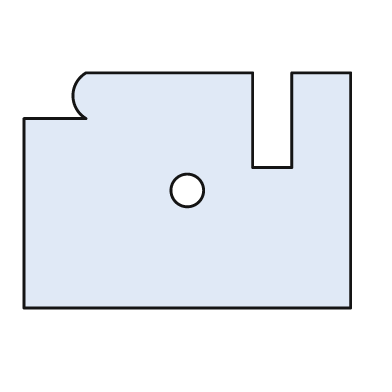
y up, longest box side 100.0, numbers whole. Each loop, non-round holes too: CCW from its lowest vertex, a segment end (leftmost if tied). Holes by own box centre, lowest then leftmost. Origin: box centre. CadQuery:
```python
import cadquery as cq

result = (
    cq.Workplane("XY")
    .moveTo(-50.0, -36.0)
    .lineTo(50.0, -36.0)
    .lineTo(50.0, 36.0)
    .lineTo(32.0, 36.0)
    .lineTo(32.0, 7.0)
    .lineTo(20.0, 7.0)
    .lineTo(20.0, 36.0)
    .lineTo(-31.0, 36.0)
    .threePointArc((-35.0, 29.0), (-31.0, 22.0))
    .lineTo(-50.0, 22.0)
    .close()
    .moveTo(0.0, 0.0)
    .circle(5.0)
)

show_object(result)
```